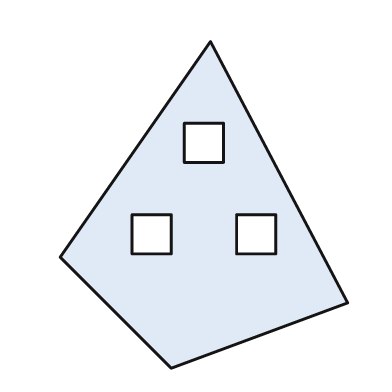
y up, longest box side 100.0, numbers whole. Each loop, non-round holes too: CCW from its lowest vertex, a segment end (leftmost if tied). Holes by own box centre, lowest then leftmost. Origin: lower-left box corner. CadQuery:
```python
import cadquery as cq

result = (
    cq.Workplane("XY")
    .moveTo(34.0, 0.0)
    .lineTo(88.0, 20.0)
    .lineTo(46.0, 100.0)
    .lineTo(0.0, 34.0)
    .close()
    .moveTo(22.0, 35.0)
    .lineTo(34.0, 35.0)
    .lineTo(34.0, 47.0)
    .lineTo(22.0, 47.0)
    .close()
    .moveTo(54.0, 35.0)
    .lineTo(66.0, 35.0)
    .lineTo(66.0, 47.0)
    .lineTo(54.0, 47.0)
    .close()
    .moveTo(38.0, 63.0)
    .lineTo(50.0, 63.0)
    .lineTo(50.0, 75.0)
    .lineTo(38.0, 75.0)
    .close()
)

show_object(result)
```